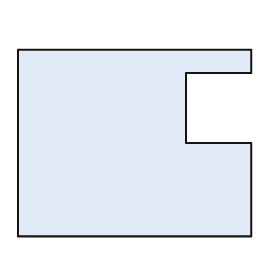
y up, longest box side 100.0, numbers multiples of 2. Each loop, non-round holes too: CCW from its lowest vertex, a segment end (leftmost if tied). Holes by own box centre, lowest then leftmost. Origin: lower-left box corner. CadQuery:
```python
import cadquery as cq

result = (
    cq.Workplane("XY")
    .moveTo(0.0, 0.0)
    .lineTo(100.0, 0.0)
    .lineTo(100.0, 40.0)
    .lineTo(72.0, 40.0)
    .lineTo(72.0, 70.0)
    .lineTo(100.0, 70.0)
    .lineTo(100.0, 80.0)
    .lineTo(0.0, 80.0)
    .close()
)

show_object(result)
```